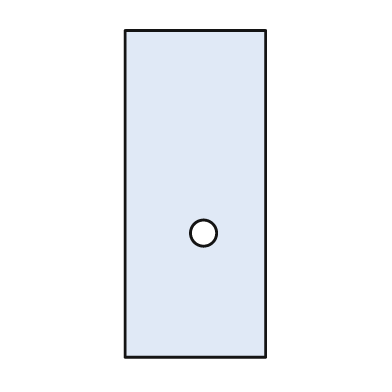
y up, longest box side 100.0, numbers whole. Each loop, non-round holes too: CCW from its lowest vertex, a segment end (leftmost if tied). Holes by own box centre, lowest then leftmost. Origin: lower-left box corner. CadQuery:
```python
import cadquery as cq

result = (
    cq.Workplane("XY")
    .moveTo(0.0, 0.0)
    .lineTo(43.0, 0.0)
    .lineTo(43.0, 100.0)
    .lineTo(0.0, 100.0)
    .close()
    .moveTo(24.0, 38.0)
    .circle(4.0)
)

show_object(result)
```